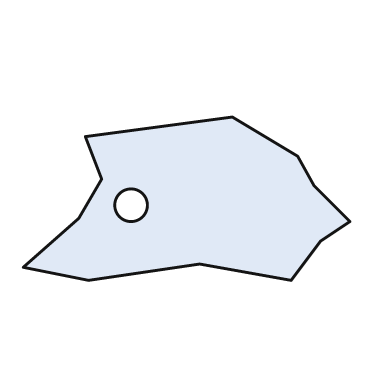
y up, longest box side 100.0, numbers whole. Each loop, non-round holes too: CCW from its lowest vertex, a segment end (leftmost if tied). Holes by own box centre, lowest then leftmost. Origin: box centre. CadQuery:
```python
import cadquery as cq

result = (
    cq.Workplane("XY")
    .moveTo(-30.0, -25.0)
    .lineTo(4.0, -20.0)
    .lineTo(32.0, -25.0)
    .lineTo(41.0, -13.0)
    .lineTo(50.0, -7.0)
    .lineTo(39.0, 4.0)
    .lineTo(34.0, 13.0)
    .lineTo(14.0, 25.0)
    .lineTo(-31.0, 19.0)
    .lineTo(-26.0, 6.0)
    .lineTo(-33.0, -6.0)
    .lineTo(-50.0, -21.0)
    .close()
    .moveTo(-17.0, -2.0)
    .circle(5.0)
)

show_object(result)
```